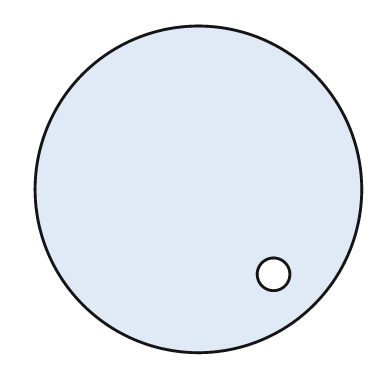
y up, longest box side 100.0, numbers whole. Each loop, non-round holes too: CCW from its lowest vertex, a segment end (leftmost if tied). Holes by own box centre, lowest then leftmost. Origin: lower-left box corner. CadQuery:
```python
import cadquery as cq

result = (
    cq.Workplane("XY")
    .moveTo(50.0, 50.0)
    .circle(50.0)
    .moveTo(73.0, 24.0)
    .circle(5.0)
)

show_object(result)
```